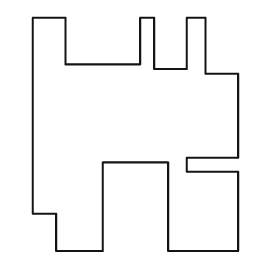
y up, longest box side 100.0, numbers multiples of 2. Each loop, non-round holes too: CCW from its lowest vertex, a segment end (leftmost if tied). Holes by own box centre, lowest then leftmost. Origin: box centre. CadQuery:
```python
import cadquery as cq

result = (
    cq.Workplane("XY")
    .moveTo(-34.0, -50.0)
    .lineTo(-14.0, -50.0)
    .lineTo(-14.0, -12.0)
    .lineTo(14.0, -12.0)
    .lineTo(14.0, -50.0)
    .lineTo(44.0, -50.0)
    .lineTo(44.0, -16.0)
    .lineTo(22.0, -16.0)
    .lineTo(22.0, -10.0)
    .lineTo(44.0, -10.0)
    .lineTo(44.0, 26.0)
    .lineTo(30.0, 26.0)
    .lineTo(30.0, 50.0)
    .lineTo(22.0, 50.0)
    .lineTo(22.0, 28.0)
    .lineTo(8.0, 28.0)
    .lineTo(8.0, 50.0)
    .lineTo(2.0, 50.0)
    .lineTo(2.0, 30.0)
    .lineTo(-30.0, 30.0)
    .lineTo(-30.0, 50.0)
    .lineTo(-44.0, 50.0)
    .lineTo(-44.0, -34.0)
    .lineTo(-34.0, -34.0)
    .close()
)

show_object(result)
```